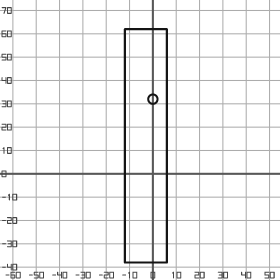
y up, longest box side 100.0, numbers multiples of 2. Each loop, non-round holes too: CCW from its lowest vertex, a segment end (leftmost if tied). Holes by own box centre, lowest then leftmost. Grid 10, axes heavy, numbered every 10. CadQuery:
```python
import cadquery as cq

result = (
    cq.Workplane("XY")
    .moveTo(-12.0, -38.0)
    .lineTo(6.0, -38.0)
    .lineTo(6.0, 62.0)
    .lineTo(-12.0, 62.0)
    .close()
    .moveTo(0.0, 32.0)
    .circle(2.0)
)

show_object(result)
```